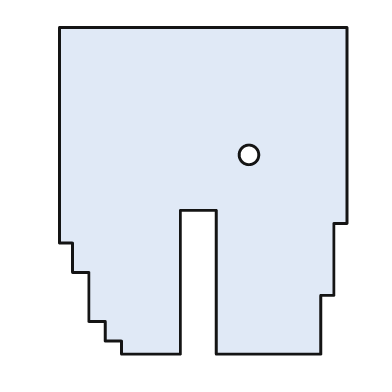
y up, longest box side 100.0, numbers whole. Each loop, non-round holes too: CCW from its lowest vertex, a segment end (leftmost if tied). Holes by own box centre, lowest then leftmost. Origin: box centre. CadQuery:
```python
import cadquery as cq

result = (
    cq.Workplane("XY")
    .moveTo(-25.0, -50.0)
    .lineTo(-7.0, -50.0)
    .lineTo(-7.0, -6.0)
    .lineTo(4.0, -6.0)
    .lineTo(4.0, -50.0)
    .lineTo(36.0, -50.0)
    .lineTo(36.0, -32.0)
    .lineTo(40.0, -32.0)
    .lineTo(40.0, -10.0)
    .lineTo(44.0, -10.0)
    .lineTo(44.0, 50.0)
    .lineTo(-44.0, 50.0)
    .lineTo(-44.0, -16.0)
    .lineTo(-40.0, -16.0)
    .lineTo(-40.0, -25.0)
    .lineTo(-35.0, -25.0)
    .lineTo(-35.0, -40.0)
    .lineTo(-30.0, -40.0)
    .lineTo(-30.0, -46.0)
    .lineTo(-25.0, -46.0)
    .close()
    .moveTo(14.0, 11.0)
    .circle(3.0)
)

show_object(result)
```